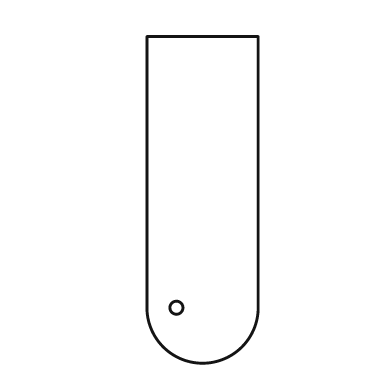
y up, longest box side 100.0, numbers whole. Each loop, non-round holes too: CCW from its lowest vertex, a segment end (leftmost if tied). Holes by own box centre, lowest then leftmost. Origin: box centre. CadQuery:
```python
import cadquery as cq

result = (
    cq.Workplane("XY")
    .moveTo(-17.0, -34.0)
    .threePointArc((0.0, -50.0), (17.0, -34.0))
    .lineTo(17.0, 50.0)
    .lineTo(-17.0, 50.0)
    .close()
    .moveTo(-8.0, -33.0)
    .circle(2.0)
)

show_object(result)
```